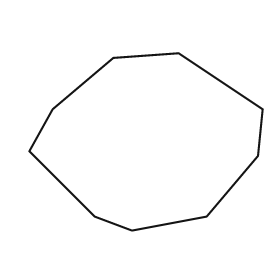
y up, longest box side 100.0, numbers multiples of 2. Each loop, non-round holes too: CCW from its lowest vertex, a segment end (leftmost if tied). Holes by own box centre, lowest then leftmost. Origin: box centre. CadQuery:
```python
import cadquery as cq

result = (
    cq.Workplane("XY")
    .moveTo(-6.0, -38.0)
    .lineTo(26.0, -32.0)
    .lineTo(48.0, -6.0)
    .lineTo(50.0, 14.0)
    .lineTo(14.0, 38.0)
    .lineTo(-14.0, 36.0)
    .lineTo(-40.0, 14.0)
    .lineTo(-50.0, -4.0)
    .lineTo(-22.0, -32.0)
    .close()
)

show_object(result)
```